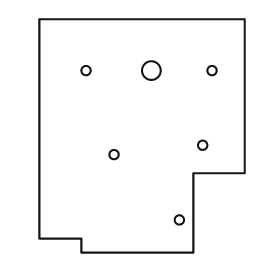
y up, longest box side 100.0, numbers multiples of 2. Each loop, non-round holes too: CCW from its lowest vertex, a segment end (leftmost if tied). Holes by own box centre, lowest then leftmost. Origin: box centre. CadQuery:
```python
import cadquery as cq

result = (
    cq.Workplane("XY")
    .moveTo(-26.0, -50.0)
    .lineTo(22.0, -50.0)
    .lineTo(22.0, -16.0)
    .lineTo(44.0, -16.0)
    .lineTo(44.0, 50.0)
    .lineTo(-44.0, 50.0)
    .lineTo(-44.0, -44.0)
    .lineTo(-26.0, -44.0)
    .close()
    .moveTo(16.0, -36.0)
    .circle(2.0)
    .moveTo(-12.0, -8.0)
    .circle(2.0)
    .moveTo(26.0, -4.0)
    .circle(2.0)
    .moveTo(-24.0, 28.0)
    .circle(2.0)
    .moveTo(4.0, 28.0)
    .circle(4.0)
    .moveTo(30.0, 28.0)
    .circle(2.0)
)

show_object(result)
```